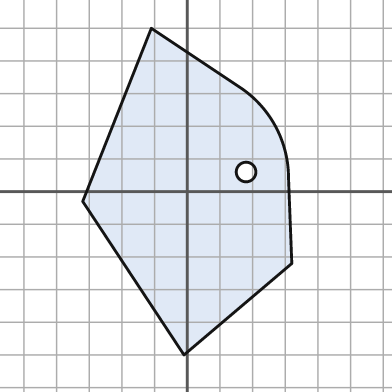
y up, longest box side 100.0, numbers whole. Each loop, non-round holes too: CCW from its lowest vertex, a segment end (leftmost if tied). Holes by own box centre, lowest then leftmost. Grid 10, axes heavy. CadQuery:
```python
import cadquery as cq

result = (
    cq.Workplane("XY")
    .moveTo(-1.0, -50.0)
    .lineTo(32.0, -22.0)
    .lineTo(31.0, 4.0)
    .threePointArc((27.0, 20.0), (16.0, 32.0))
    .lineTo(-11.0, 50.0)
    .lineTo(-32.0, -3.0)
    .close()
    .moveTo(18.0, 6.0)
    .circle(3.0)
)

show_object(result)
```